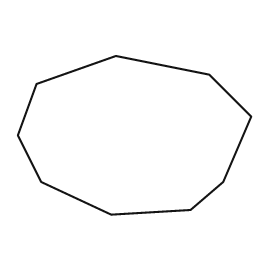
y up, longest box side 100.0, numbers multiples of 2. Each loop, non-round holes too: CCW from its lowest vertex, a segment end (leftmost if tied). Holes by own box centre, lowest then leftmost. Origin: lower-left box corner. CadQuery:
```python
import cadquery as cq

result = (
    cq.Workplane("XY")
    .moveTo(40.0, 0.0)
    .lineTo(74.0, 2.0)
    .lineTo(88.0, 14.0)
    .lineTo(100.0, 42.0)
    .lineTo(82.0, 60.0)
    .lineTo(42.0, 68.0)
    .lineTo(8.0, 56.0)
    .lineTo(0.0, 34.0)
    .lineTo(10.0, 14.0)
    .close()
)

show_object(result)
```